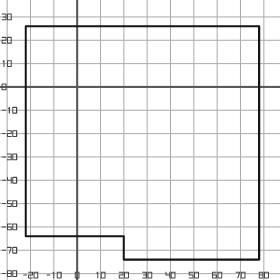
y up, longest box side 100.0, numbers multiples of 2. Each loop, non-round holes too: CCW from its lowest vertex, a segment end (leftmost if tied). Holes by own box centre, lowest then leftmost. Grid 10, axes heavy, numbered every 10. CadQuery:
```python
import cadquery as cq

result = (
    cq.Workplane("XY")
    .moveTo(20.0, -74.0)
    .lineTo(78.0, -74.0)
    .lineTo(78.0, 26.0)
    .lineTo(-22.0, 26.0)
    .lineTo(-22.0, -64.0)
    .lineTo(20.0, -64.0)
    .close()
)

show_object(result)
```